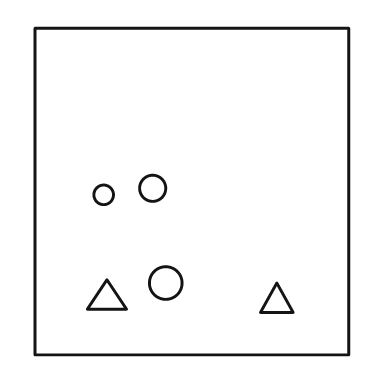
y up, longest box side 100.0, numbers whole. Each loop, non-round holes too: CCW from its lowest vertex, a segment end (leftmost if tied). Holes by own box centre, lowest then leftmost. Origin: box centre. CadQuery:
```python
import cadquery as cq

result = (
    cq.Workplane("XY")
    .moveTo(-48.0, -50.0)
    .lineTo(48.0, -50.0)
    .lineTo(48.0, 50.0)
    .lineTo(-48.0, 50.0)
    .close()
    .moveTo(21.0, -37.0)
    .lineTo(31.0, -37.0)
    .lineTo(26.0, -28.0)
    .close()
    .moveTo(-32.0, -36.0)
    .lineTo(-20.0, -36.0)
    .lineTo(-26.0, -27.0)
    .close()
    .moveTo(-8.0, -28.0)
    .circle(5.0)
    .moveTo(-27.0, -1.0)
    .circle(3.0)
    .moveTo(-12.0, 1.0)
    .circle(4.0)
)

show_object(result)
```